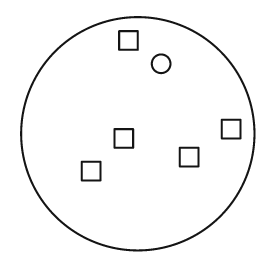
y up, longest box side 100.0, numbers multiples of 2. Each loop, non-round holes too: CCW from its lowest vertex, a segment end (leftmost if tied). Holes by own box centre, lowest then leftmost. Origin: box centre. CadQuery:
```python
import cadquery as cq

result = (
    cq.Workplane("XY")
    .moveTo(0.0, 0.0)
    .circle(50.0)
    .moveTo(-24.0, -20.0)
    .lineTo(-16.0, -20.0)
    .lineTo(-16.0, -12.0)
    .lineTo(-24.0, -12.0)
    .close()
    .moveTo(18.0, -14.0)
    .lineTo(26.0, -14.0)
    .lineTo(26.0, -6.0)
    .lineTo(18.0, -6.0)
    .close()
    .moveTo(-10.0, -6.0)
    .lineTo(-2.0, -6.0)
    .lineTo(-2.0, 2.0)
    .lineTo(-10.0, 2.0)
    .close()
    .moveTo(36.0, -2.0)
    .lineTo(44.0, -2.0)
    .lineTo(44.0, 6.0)
    .lineTo(36.0, 6.0)
    .close()
    .moveTo(10.0, 30.0)
    .circle(4.0)
    .moveTo(-8.0, 36.0)
    .lineTo(0.0, 36.0)
    .lineTo(0.0, 44.0)
    .lineTo(-8.0, 44.0)
    .close()
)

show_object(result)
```